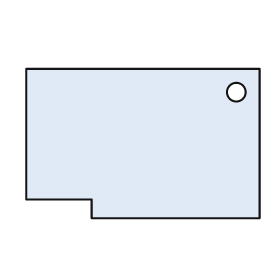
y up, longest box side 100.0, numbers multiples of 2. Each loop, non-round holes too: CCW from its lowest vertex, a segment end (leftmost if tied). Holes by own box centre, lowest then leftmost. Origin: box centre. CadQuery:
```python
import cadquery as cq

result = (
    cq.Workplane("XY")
    .moveTo(-22.0, -32.0)
    .lineTo(50.0, -32.0)
    .lineTo(50.0, 32.0)
    .lineTo(-50.0, 32.0)
    .lineTo(-50.0, -24.0)
    .lineTo(-22.0, -24.0)
    .close()
    .moveTo(40.0, 22.0)
    .circle(4.0)
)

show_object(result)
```